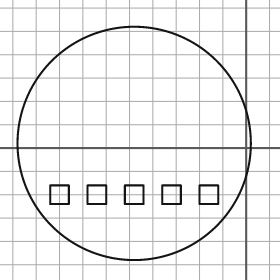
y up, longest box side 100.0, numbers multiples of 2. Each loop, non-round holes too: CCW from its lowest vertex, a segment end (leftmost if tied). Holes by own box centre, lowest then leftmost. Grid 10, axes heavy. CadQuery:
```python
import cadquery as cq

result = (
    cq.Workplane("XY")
    .moveTo(-48.0, 2.0)
    .circle(50.0)
    .moveTo(-84.0, -24.0)
    .lineTo(-76.0, -24.0)
    .lineTo(-76.0, -16.0)
    .lineTo(-84.0, -16.0)
    .close()
    .moveTo(-68.0, -24.0)
    .lineTo(-60.0, -24.0)
    .lineTo(-60.0, -16.0)
    .lineTo(-68.0, -16.0)
    .close()
    .moveTo(-52.0, -24.0)
    .lineTo(-44.0, -24.0)
    .lineTo(-44.0, -16.0)
    .lineTo(-52.0, -16.0)
    .close()
    .moveTo(-36.0, -24.0)
    .lineTo(-28.0, -24.0)
    .lineTo(-28.0, -16.0)
    .lineTo(-36.0, -16.0)
    .close()
    .moveTo(-20.0, -24.0)
    .lineTo(-12.0, -24.0)
    .lineTo(-12.0, -16.0)
    .lineTo(-20.0, -16.0)
    .close()
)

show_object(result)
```